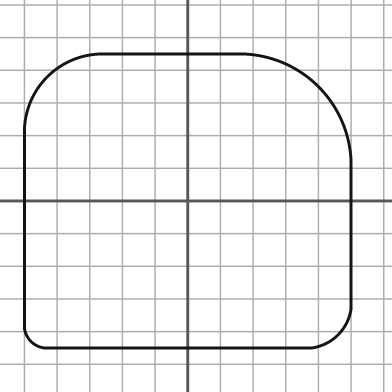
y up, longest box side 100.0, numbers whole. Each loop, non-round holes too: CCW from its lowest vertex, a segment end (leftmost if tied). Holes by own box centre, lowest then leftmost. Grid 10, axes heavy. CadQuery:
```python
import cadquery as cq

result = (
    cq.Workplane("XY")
    .moveTo(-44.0, -45.0)
    .lineTo(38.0, -45.0)
    .threePointArc((46.0, -41.0), (50.0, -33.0))
    .lineTo(50.0, 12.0)
    .threePointArc((40.0, 35.0), (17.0, 45.0))
    .lineTo(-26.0, 45.0)
    .threePointArc((-43.0, 38.0), (-50.0, 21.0))
    .lineTo(-50.0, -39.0)
    .threePointArc((-48.0, -43.0), (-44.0, -45.0))
    .close()
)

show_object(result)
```